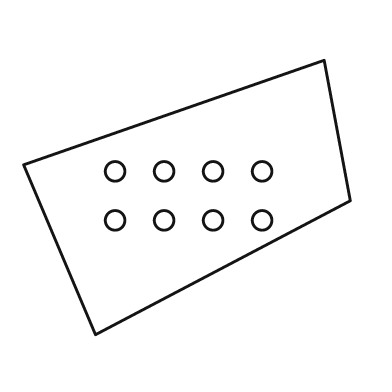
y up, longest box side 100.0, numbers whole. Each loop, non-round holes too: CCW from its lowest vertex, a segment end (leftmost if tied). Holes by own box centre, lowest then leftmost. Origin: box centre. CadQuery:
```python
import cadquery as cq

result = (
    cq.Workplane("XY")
    .moveTo(-28.0, -42.0)
    .lineTo(50.0, -1.0)
    .lineTo(42.0, 42.0)
    .lineTo(-50.0, 10.0)
    .close()
    .moveTo(-22.0, -7.0)
    .circle(3.0)
    .moveTo(-7.0, -7.0)
    .circle(3.0)
    .moveTo(8.0, -7.0)
    .circle(3.0)
    .moveTo(23.0, -7.0)
    .circle(3.0)
    .moveTo(-22.0, 8.0)
    .circle(3.0)
    .moveTo(-7.0, 8.0)
    .circle(3.0)
    .moveTo(8.0, 8.0)
    .circle(3.0)
    .moveTo(23.0, 8.0)
    .circle(3.0)
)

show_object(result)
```